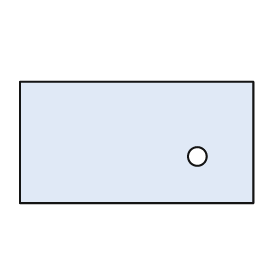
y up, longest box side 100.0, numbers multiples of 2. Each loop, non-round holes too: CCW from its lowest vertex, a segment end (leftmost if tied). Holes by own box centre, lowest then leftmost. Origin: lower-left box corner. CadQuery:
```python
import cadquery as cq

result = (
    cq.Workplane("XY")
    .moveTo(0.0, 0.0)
    .lineTo(100.0, 0.0)
    .lineTo(100.0, 52.0)
    .lineTo(0.0, 52.0)
    .close()
    .moveTo(76.0, 20.0)
    .circle(4.0)
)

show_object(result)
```